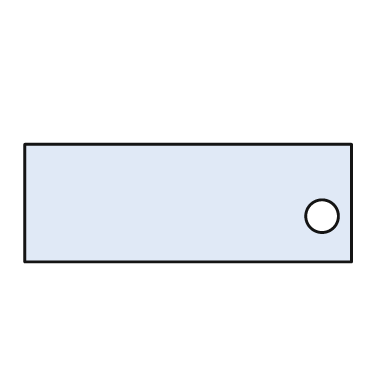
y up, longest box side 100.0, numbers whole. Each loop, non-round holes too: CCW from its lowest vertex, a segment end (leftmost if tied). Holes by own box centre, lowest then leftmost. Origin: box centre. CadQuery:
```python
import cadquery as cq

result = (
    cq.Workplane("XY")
    .moveTo(-50.0, -18.0)
    .lineTo(50.0, -18.0)
    .lineTo(50.0, 18.0)
    .lineTo(-50.0, 18.0)
    .close()
    .moveTo(41.0, -4.0)
    .circle(5.0)
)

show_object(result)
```